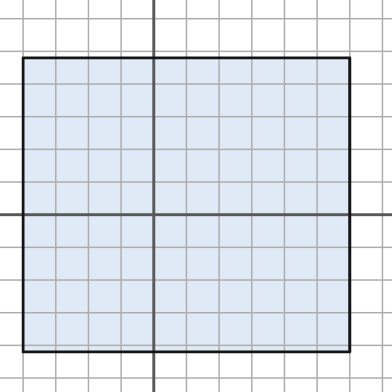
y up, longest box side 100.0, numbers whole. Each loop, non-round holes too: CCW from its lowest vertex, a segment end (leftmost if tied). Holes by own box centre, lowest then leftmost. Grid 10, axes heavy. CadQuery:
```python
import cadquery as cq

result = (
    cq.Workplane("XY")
    .moveTo(-40.0, -42.0)
    .lineTo(60.0, -42.0)
    .lineTo(60.0, 48.0)
    .lineTo(-40.0, 48.0)
    .close()
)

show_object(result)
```